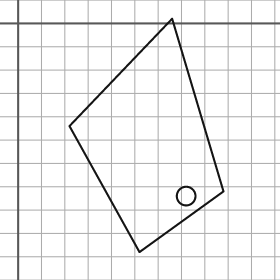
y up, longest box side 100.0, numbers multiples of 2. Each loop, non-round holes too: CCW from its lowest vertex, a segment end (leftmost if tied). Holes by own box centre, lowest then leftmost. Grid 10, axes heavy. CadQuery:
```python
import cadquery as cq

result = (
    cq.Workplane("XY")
    .moveTo(52.0, -98.0)
    .lineTo(88.0, -72.0)
    .lineTo(66.0, 2.0)
    .lineTo(22.0, -44.0)
    .close()
    .moveTo(72.0, -74.0)
    .circle(4.0)
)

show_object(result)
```